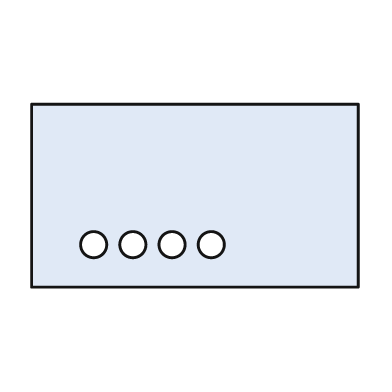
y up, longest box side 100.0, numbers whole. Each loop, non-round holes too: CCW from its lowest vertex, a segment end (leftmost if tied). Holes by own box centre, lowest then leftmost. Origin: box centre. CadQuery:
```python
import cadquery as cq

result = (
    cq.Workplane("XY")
    .moveTo(-50.0, -28.0)
    .lineTo(50.0, -28.0)
    .lineTo(50.0, 28.0)
    .lineTo(-50.0, 28.0)
    .close()
    .moveTo(-31.0, -15.0)
    .circle(4.0)
    .moveTo(-19.0, -15.0)
    .circle(4.0)
    .moveTo(-7.0, -15.0)
    .circle(4.0)
    .moveTo(5.0, -15.0)
    .circle(4.0)
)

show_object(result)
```